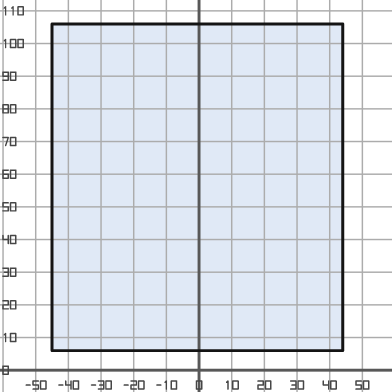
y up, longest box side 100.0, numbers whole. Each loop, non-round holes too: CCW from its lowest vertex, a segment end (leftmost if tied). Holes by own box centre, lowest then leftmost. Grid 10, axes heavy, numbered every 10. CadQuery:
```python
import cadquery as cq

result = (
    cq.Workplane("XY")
    .moveTo(-45.0, 6.0)
    .lineTo(44.0, 6.0)
    .lineTo(44.0, 106.0)
    .lineTo(-45.0, 106.0)
    .close()
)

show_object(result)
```